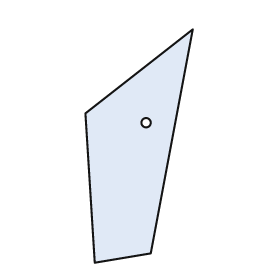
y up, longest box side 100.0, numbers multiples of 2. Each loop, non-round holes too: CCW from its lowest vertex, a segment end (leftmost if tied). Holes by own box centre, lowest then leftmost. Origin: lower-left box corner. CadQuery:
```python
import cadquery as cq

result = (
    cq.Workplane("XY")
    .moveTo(4.0, 0.0)
    .lineTo(28.0, 4.0)
    .lineTo(46.0, 100.0)
    .lineTo(0.0, 64.0)
    .close()
    .moveTo(26.0, 60.0)
    .circle(2.0)
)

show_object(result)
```